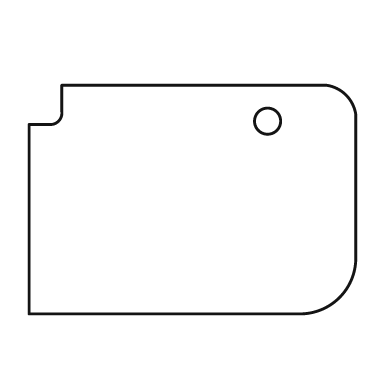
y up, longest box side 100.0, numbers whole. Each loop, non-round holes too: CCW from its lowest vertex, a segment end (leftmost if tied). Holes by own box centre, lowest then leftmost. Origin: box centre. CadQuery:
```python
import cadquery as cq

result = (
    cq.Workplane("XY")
    .moveTo(-50.0, -35.0)
    .lineTo(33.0, -35.0)
    .threePointArc((45.0, -30.0), (50.0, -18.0))
    .lineTo(50.0, 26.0)
    .threePointArc((47.0, 32.0), (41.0, 35.0))
    .lineTo(-40.0, 35.0)
    .lineTo(-40.0, 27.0)
    .threePointArc((-41.0, 24.0), (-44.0, 23.0))
    .lineTo(-50.0, 23.0)
    .close()
    .moveTo(23.0, 24.0)
    .circle(4.0)
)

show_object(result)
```